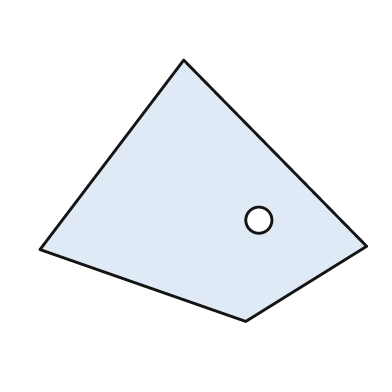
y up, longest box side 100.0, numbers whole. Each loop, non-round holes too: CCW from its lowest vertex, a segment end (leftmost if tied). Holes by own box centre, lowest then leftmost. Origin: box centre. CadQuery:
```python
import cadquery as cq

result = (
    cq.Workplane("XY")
    .moveTo(13.0, -40.0)
    .lineTo(50.0, -17.0)
    .lineTo(-6.0, 40.0)
    .lineTo(-50.0, -18.0)
    .close()
    .moveTo(17.0, -9.0)
    .circle(4.0)
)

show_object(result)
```